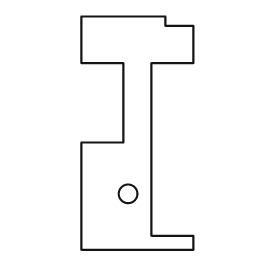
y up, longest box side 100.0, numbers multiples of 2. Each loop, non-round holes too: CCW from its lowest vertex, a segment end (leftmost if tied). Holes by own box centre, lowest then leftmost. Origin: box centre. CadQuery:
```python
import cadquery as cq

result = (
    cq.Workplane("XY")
    .moveTo(-24.0, -50.0)
    .lineTo(24.0, -50.0)
    .lineTo(24.0, -44.0)
    .lineTo(6.0, -44.0)
    .lineTo(6.0, 30.0)
    .lineTo(24.0, 30.0)
    .lineTo(24.0, 46.0)
    .lineTo(12.0, 46.0)
    .lineTo(12.0, 50.0)
    .lineTo(-24.0, 50.0)
    .lineTo(-24.0, 30.0)
    .lineTo(-6.0, 30.0)
    .lineTo(-6.0, -4.0)
    .lineTo(-24.0, -4.0)
    .close()
    .moveTo(-4.0, -26.0)
    .circle(4.0)
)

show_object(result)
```